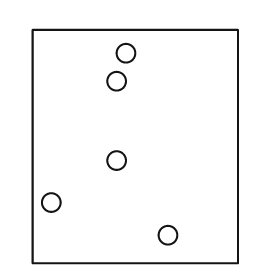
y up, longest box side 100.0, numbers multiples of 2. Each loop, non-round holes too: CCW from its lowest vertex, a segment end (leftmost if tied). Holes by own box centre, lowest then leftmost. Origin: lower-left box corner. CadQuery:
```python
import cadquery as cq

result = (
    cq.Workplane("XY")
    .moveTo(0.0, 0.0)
    .lineTo(88.0, 0.0)
    .lineTo(88.0, 100.0)
    .lineTo(0.0, 100.0)
    .close()
    .moveTo(58.0, 12.0)
    .circle(4.0)
    .moveTo(8.0, 26.0)
    .circle(4.0)
    .moveTo(36.0, 44.0)
    .circle(4.0)
    .moveTo(36.0, 78.0)
    .circle(4.0)
    .moveTo(40.0, 90.0)
    .circle(4.0)
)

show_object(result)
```